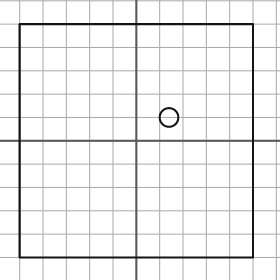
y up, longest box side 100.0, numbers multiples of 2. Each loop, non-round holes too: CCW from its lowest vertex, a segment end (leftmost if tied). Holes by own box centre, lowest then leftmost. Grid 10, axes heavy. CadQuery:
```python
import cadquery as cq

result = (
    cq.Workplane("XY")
    .moveTo(-50.0, -50.0)
    .lineTo(50.0, -50.0)
    .lineTo(50.0, 50.0)
    .lineTo(-50.0, 50.0)
    .close()
    .moveTo(14.0, 10.0)
    .circle(4.0)
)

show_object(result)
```